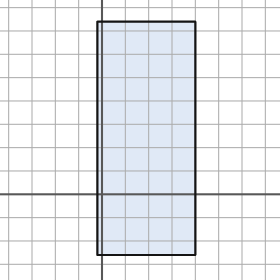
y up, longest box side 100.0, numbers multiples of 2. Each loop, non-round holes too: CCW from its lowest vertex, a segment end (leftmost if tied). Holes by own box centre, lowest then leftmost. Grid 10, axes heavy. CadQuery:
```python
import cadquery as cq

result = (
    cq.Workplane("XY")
    .moveTo(-2.0, -26.0)
    .lineTo(40.0, -26.0)
    .lineTo(40.0, 74.0)
    .lineTo(-2.0, 74.0)
    .close()
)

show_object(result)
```